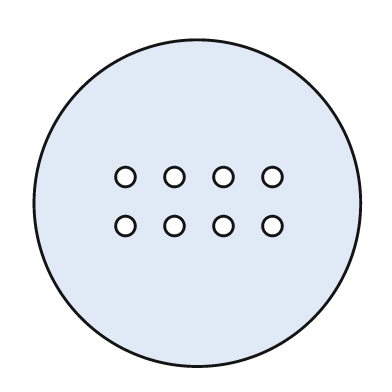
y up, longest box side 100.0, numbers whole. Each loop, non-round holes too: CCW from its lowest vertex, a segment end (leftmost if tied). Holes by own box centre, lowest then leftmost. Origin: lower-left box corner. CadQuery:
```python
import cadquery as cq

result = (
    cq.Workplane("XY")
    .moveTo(50.0, 50.0)
    .circle(50.0)
    .moveTo(28.0, 43.0)
    .circle(3.0)
    .moveTo(43.0, 43.0)
    .circle(3.0)
    .moveTo(58.0, 43.0)
    .circle(3.0)
    .moveTo(73.0, 43.0)
    .circle(3.0)
    .moveTo(28.0, 58.0)
    .circle(3.0)
    .moveTo(43.0, 58.0)
    .circle(3.0)
    .moveTo(58.0, 58.0)
    .circle(3.0)
    .moveTo(73.0, 58.0)
    .circle(3.0)
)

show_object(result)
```